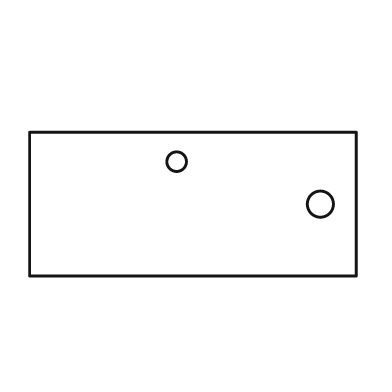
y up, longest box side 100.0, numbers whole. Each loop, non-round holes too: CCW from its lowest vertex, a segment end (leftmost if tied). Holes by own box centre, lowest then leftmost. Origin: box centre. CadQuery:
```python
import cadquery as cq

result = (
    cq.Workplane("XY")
    .moveTo(-50.0, -22.0)
    .lineTo(50.0, -22.0)
    .lineTo(50.0, 22.0)
    .lineTo(-50.0, 22.0)
    .close()
    .moveTo(39.0, 0.0)
    .circle(4.0)
    .moveTo(-5.0, 13.0)
    .circle(3.0)
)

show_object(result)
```